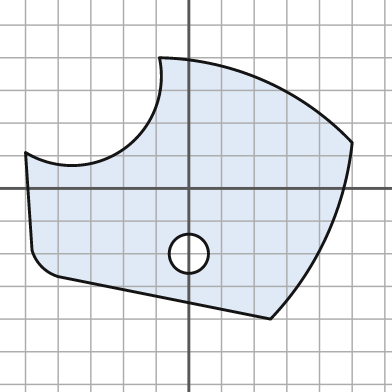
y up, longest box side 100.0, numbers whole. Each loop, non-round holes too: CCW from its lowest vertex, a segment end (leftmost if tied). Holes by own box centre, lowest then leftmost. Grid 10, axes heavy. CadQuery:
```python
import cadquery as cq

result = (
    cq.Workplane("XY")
    .moveTo(25.0, -40.0)
    .threePointArc((42.0, -15.0), (50.0, 14.0))
    .threePointArc((23.0, 33.0), (-9.0, 40.0))
    .threePointArc((-20.0, 12.0), (-50.0, 11.0))
    .lineTo(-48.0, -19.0)
    .threePointArc((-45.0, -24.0), (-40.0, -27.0))
    .close()
    .moveTo(0.0, -20.0)
    .circle(6.0)
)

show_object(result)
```